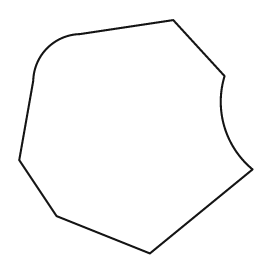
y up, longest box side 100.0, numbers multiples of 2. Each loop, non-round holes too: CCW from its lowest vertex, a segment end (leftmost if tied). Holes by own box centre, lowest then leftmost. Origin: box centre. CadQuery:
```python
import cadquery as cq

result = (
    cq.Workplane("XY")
    .moveTo(6.0, -50.0)
    .lineTo(50.0, -14.0)
    .threePointArc((38.0, 4.0), (38.0, 26.0))
    .lineTo(16.0, 50.0)
    .lineTo(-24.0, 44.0)
    .threePointArc((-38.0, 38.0), (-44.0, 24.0))
    .lineTo(-50.0, -10.0)
    .lineTo(-34.0, -34.0)
    .close()
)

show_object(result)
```